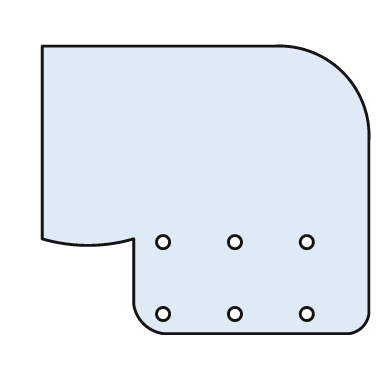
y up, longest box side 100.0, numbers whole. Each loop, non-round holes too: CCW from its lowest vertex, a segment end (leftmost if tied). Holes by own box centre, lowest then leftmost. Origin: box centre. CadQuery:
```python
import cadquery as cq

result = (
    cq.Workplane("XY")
    .moveTo(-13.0, -44.0)
    .lineTo(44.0, -44.0)
    .threePointArc((48.0, -42.0), (50.0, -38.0))
    .lineTo(50.0, 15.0)
    .threePointArc((42.0, 36.0), (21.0, 44.0))
    .lineTo(-50.0, 44.0)
    .lineTo(-50.0, -15.0)
    .threePointArc((-36.0, -17.0), (-22.0, -15.0))
    .lineTo(-22.0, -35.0)
    .threePointArc((-19.0, -41.0), (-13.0, -44.0))
    .close()
    .moveTo(-13.0, -38.0)
    .circle(2.0)
    .moveTo(9.0, -38.0)
    .circle(2.0)
    .moveTo(31.0, -38.0)
    .circle(2.0)
    .moveTo(-13.0, -16.0)
    .circle(2.0)
    .moveTo(9.0, -16.0)
    .circle(2.0)
    .moveTo(31.0, -16.0)
    .circle(2.0)
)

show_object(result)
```